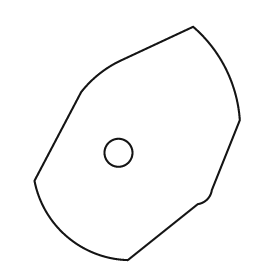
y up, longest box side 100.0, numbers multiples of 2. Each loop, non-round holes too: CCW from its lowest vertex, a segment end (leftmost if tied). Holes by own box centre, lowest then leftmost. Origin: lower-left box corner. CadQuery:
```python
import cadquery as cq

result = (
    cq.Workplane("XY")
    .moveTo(40.0, 0.0)
    .lineTo(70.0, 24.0)
    .threePointArc((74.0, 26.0), (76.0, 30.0))
    .lineTo(88.0, 60.0)
    .threePointArc((82.0, 82.0), (68.0, 100.0))
    .lineTo(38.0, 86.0)
    .threePointArc((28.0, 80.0), (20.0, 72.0))
    .lineTo(0.0, 34.0)
    .threePointArc((14.0, 10.0), (40.0, 0.0))
    .close()
    .moveTo(36.0, 46.0)
    .circle(6.0)
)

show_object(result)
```